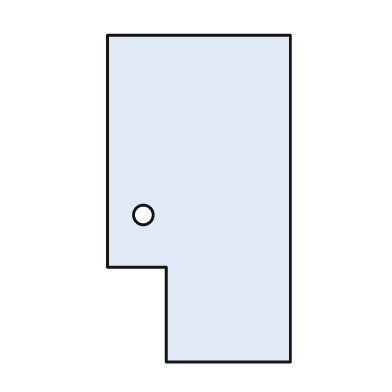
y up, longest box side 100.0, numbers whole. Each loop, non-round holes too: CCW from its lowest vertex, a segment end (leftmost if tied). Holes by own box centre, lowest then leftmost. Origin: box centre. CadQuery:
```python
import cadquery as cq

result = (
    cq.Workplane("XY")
    .moveTo(-10.0, -50.0)
    .lineTo(28.0, -50.0)
    .lineTo(28.0, 50.0)
    .lineTo(-28.0, 50.0)
    .lineTo(-28.0, -21.0)
    .lineTo(-10.0, -21.0)
    .close()
    .moveTo(-17.0, -5.0)
    .circle(3.0)
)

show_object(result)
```